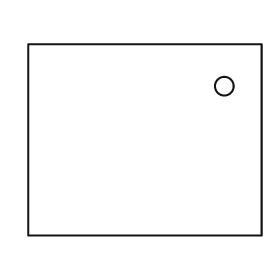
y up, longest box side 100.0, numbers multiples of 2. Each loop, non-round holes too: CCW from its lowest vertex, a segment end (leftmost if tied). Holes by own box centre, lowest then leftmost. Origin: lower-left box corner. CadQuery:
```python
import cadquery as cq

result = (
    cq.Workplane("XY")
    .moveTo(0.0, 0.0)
    .lineTo(100.0, 0.0)
    .lineTo(100.0, 82.0)
    .lineTo(0.0, 82.0)
    .close()
    .moveTo(84.0, 64.0)
    .circle(4.0)
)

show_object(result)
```